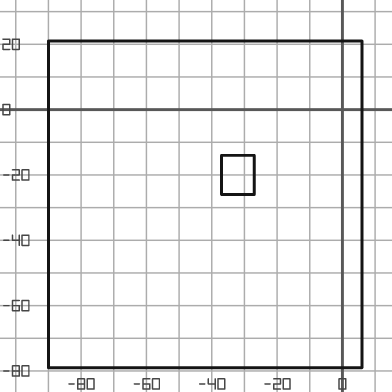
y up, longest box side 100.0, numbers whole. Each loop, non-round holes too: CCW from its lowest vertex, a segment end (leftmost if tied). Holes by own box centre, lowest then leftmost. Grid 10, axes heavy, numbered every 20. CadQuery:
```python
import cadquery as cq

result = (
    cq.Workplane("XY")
    .moveTo(-90.0, -79.0)
    .lineTo(6.0, -79.0)
    .lineTo(6.0, 21.0)
    .lineTo(-90.0, 21.0)
    .close()
    .moveTo(-37.0, -26.0)
    .lineTo(-27.0, -26.0)
    .lineTo(-27.0, -14.0)
    .lineTo(-37.0, -14.0)
    .close()
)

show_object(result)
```